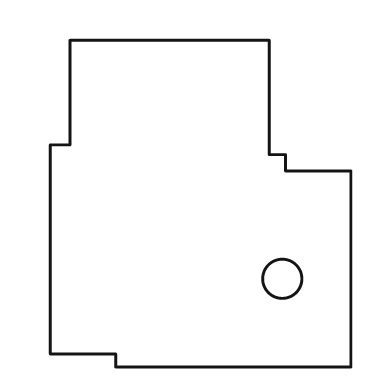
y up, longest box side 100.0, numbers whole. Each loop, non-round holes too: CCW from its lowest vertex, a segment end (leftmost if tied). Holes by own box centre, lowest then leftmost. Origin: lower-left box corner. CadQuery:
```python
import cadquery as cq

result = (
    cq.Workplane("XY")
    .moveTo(20.0, 0.0)
    .lineTo(92.0, 0.0)
    .lineTo(92.0, 60.0)
    .lineTo(72.0, 60.0)
    .lineTo(72.0, 65.0)
    .lineTo(67.0, 65.0)
    .lineTo(67.0, 100.0)
    .lineTo(6.0, 100.0)
    .lineTo(6.0, 68.0)
    .lineTo(0.0, 68.0)
    .lineTo(0.0, 4.0)
    .lineTo(20.0, 4.0)
    .close()
    .moveTo(71.0, 27.0)
    .circle(6.0)
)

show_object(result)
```